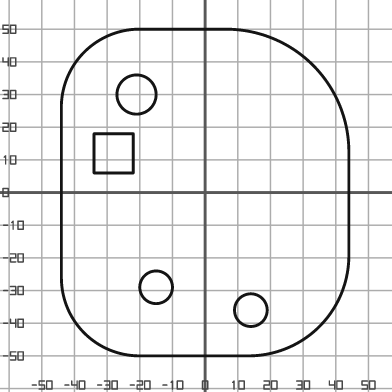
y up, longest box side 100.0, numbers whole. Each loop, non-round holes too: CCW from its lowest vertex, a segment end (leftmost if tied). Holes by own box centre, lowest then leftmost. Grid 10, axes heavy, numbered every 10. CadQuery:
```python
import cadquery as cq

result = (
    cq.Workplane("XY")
    .moveTo(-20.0, -50.0)
    .lineTo(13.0, -50.0)
    .threePointArc((35.0, -41.0), (44.0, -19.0))
    .lineTo(44.0, 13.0)
    .threePointArc((33.0, 39.0), (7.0, 50.0))
    .lineTo(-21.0, 50.0)
    .threePointArc((-37.0, 43.0), (-44.0, 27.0))
    .lineTo(-44.0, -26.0)
    .threePointArc((-37.0, -43.0), (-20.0, -50.0))
    .close()
    .moveTo(14.0, -36.0)
    .circle(5.0)
    .moveTo(-15.0, -29.0)
    .circle(5.0)
    .moveTo(-34.0, 6.0)
    .lineTo(-22.0, 6.0)
    .lineTo(-22.0, 18.0)
    .lineTo(-34.0, 18.0)
    .close()
    .moveTo(-21.0, 30.0)
    .circle(6.0)
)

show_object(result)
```